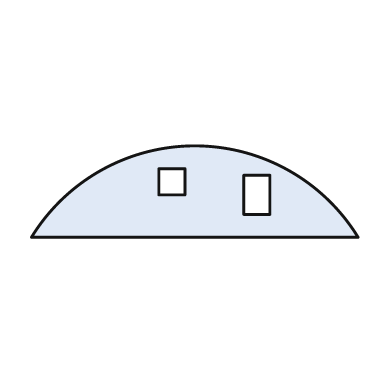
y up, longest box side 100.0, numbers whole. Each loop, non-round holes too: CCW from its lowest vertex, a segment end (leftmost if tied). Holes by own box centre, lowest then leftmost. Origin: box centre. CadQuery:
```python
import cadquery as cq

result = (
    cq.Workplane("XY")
    .moveTo(-50.0, -14.0)
    .lineTo(50.0, -14.0)
    .threePointArc((0.0, 14.0), (-50.0, -14.0))
    .close()
    .moveTo(15.0, -7.0)
    .lineTo(23.0, -7.0)
    .lineTo(23.0, 5.0)
    .lineTo(15.0, 5.0)
    .close()
    .moveTo(-11.0, -1.0)
    .lineTo(-3.0, -1.0)
    .lineTo(-3.0, 7.0)
    .lineTo(-11.0, 7.0)
    .close()
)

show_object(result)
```